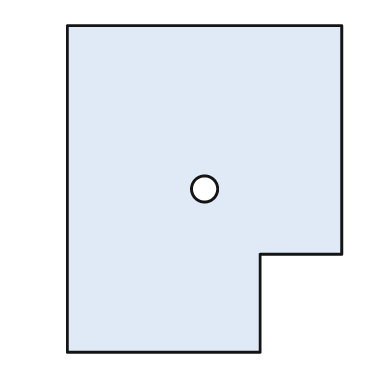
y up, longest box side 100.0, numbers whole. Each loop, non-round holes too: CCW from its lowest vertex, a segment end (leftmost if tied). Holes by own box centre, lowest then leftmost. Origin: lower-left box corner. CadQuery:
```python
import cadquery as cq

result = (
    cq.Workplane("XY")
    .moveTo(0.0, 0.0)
    .lineTo(59.0, 0.0)
    .lineTo(59.0, 30.0)
    .lineTo(84.0, 30.0)
    .lineTo(84.0, 100.0)
    .lineTo(0.0, 100.0)
    .close()
    .moveTo(42.0, 50.0)
    .circle(4.0)
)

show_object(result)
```